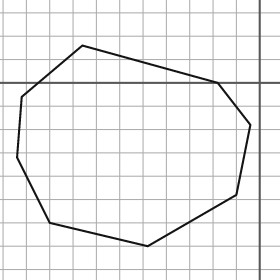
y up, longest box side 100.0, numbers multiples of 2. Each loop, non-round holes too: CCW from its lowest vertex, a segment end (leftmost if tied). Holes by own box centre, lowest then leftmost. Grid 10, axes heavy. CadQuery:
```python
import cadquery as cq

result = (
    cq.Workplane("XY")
    .moveTo(-48.0, -70.0)
    .lineTo(-10.0, -48.0)
    .lineTo(-4.0, -18.0)
    .lineTo(-18.0, 0.0)
    .lineTo(-76.0, 16.0)
    .lineTo(-102.0, -6.0)
    .lineTo(-104.0, -32.0)
    .lineTo(-90.0, -60.0)
    .close()
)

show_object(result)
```